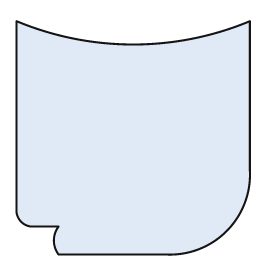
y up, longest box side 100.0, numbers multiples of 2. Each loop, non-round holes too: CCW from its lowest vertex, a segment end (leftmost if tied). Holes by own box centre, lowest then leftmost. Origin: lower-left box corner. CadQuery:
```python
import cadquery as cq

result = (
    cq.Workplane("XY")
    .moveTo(18.0, 0.0)
    .lineTo(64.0, 0.0)
    .threePointArc((90.0, 10.0), (100.0, 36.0))
    .lineTo(100.0, 100.0)
    .threePointArc((50.0, 90.0), (0.0, 100.0))
    .lineTo(0.0, 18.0)
    .threePointArc((2.0, 14.0), (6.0, 12.0))
    .lineTo(18.0, 12.0)
    .threePointArc((16.0, 6.0), (18.0, 0.0))
    .close()
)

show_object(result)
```